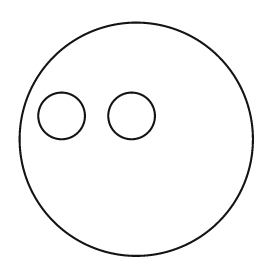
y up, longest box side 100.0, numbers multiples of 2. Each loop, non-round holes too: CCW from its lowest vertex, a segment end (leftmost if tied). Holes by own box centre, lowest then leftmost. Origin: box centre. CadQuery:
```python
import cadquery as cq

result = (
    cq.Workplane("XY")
    .moveTo(0.0, 0.0)
    .circle(50.0)
    .moveTo(-32.0, 10.0)
    .circle(10.0)
    .moveTo(-2.0, 10.0)
    .circle(10.0)
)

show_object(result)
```